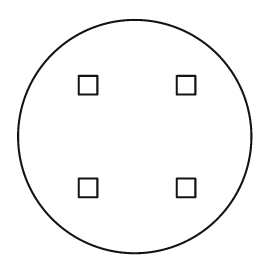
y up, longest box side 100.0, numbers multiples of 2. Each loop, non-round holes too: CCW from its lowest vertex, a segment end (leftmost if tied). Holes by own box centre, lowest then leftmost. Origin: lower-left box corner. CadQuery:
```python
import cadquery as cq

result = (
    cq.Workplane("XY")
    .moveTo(50.0, 50.0)
    .circle(50.0)
    .moveTo(26.0, 24.0)
    .lineTo(34.0, 24.0)
    .lineTo(34.0, 32.0)
    .lineTo(26.0, 32.0)
    .close()
    .moveTo(68.0, 24.0)
    .lineTo(76.0, 24.0)
    .lineTo(76.0, 32.0)
    .lineTo(68.0, 32.0)
    .close()
    .moveTo(26.0, 68.0)
    .lineTo(34.0, 68.0)
    .lineTo(34.0, 76.0)
    .lineTo(26.0, 76.0)
    .close()
    .moveTo(68.0, 68.0)
    .lineTo(76.0, 68.0)
    .lineTo(76.0, 76.0)
    .lineTo(68.0, 76.0)
    .close()
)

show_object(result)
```